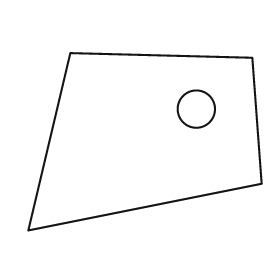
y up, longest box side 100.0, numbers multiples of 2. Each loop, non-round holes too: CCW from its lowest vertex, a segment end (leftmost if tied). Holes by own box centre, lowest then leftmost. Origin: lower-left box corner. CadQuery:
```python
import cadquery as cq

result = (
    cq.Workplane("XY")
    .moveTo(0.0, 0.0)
    .lineTo(100.0, 20.0)
    .lineTo(96.0, 74.0)
    .lineTo(18.0, 76.0)
    .close()
    .moveTo(72.0, 52.0)
    .circle(8.0)
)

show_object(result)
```